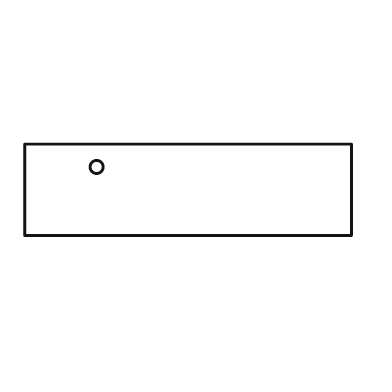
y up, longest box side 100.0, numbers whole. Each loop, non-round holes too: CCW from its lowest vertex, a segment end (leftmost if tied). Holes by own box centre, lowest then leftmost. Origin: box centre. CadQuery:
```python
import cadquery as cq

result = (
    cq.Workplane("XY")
    .moveTo(-50.0, -14.0)
    .lineTo(50.0, -14.0)
    .lineTo(50.0, 14.0)
    .lineTo(-50.0, 14.0)
    .close()
    .moveTo(-28.0, 7.0)
    .circle(2.0)
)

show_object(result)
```